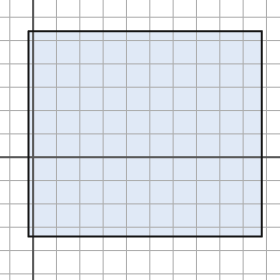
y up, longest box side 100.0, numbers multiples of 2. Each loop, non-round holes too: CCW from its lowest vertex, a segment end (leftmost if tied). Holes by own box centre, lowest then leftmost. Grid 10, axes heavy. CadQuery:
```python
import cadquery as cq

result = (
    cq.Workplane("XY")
    .moveTo(-2.0, -34.0)
    .lineTo(98.0, -34.0)
    .lineTo(98.0, 54.0)
    .lineTo(-2.0, 54.0)
    .close()
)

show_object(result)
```